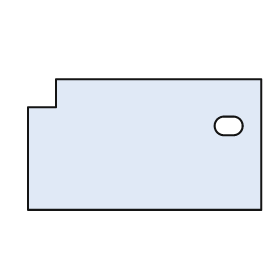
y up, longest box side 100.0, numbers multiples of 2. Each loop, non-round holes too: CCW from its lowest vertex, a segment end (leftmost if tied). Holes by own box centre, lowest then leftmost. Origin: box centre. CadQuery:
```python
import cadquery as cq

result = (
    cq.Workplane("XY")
    .moveTo(-50.0, -28.0)
    .lineTo(50.0, -28.0)
    .lineTo(50.0, 28.0)
    .lineTo(-38.0, 28.0)
    .lineTo(-38.0, 16.0)
    .lineTo(-50.0, 16.0)
    .close()
    .moveTo(34.0, 4.0)
    .lineTo(38.0, 4.0)
    .threePointArc((42.0, 8.0), (38.0, 12.0))
    .lineTo(34.0, 12.0)
    .threePointArc((30.0, 8.0), (34.0, 4.0))
    .close()
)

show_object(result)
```